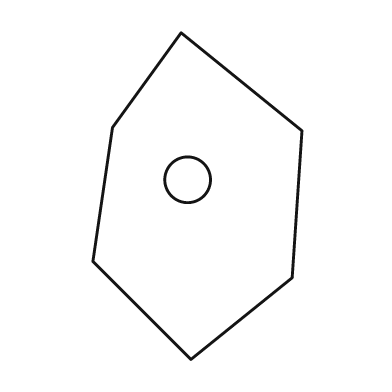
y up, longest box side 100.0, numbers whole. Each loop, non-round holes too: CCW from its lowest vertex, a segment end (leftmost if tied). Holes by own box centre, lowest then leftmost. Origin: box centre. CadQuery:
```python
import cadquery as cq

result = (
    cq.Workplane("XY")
    .moveTo(-2.0, -50.0)
    .lineTo(29.0, -25.0)
    .lineTo(32.0, 20.0)
    .lineTo(-5.0, 50.0)
    .lineTo(-26.0, 21.0)
    .lineTo(-32.0, -20.0)
    .close()
    .moveTo(-3.0, 5.0)
    .circle(7.0)
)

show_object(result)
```